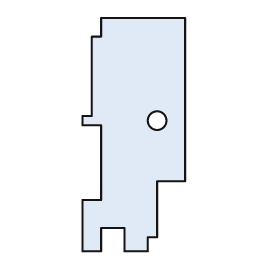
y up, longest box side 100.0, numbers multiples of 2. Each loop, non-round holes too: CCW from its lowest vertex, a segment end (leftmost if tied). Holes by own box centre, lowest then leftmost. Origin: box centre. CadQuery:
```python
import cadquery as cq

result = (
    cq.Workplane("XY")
    .moveTo(-22.0, -50.0)
    .lineTo(-14.0, -50.0)
    .lineTo(-14.0, -40.0)
    .lineTo(-4.0, -40.0)
    .lineTo(-4.0, -50.0)
    .lineTo(6.0, -50.0)
    .lineTo(6.0, -44.0)
    .lineTo(10.0, -44.0)
    .lineTo(10.0, -20.0)
    .lineTo(22.0, -20.0)
    .lineTo(22.0, 50.0)
    .lineTo(-14.0, 50.0)
    .lineTo(-14.0, 42.0)
    .lineTo(-18.0, 42.0)
    .lineTo(-18.0, 8.0)
    .lineTo(-22.0, 8.0)
    .lineTo(-22.0, 4.0)
    .lineTo(-14.0, 4.0)
    .lineTo(-14.0, -28.0)
    .lineTo(-22.0, -28.0)
    .close()
    .moveTo(10.0, 6.0)
    .circle(4.0)
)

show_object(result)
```